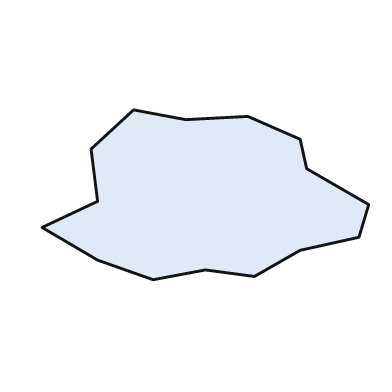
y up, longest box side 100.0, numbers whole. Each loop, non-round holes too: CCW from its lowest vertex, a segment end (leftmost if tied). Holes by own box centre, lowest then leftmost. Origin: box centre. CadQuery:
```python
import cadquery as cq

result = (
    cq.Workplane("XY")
    .moveTo(-16.0, -26.0)
    .lineTo(0.0, -23.0)
    .lineTo(15.0, -25.0)
    .lineTo(29.0, -17.0)
    .lineTo(47.0, -13.0)
    .lineTo(50.0, -3.0)
    .lineTo(31.0, 8.0)
    .lineTo(29.0, 17.0)
    .lineTo(13.0, 24.0)
    .lineTo(-6.0, 23.0)
    .lineTo(-22.0, 26.0)
    .lineTo(-35.0, 14.0)
    .lineTo(-33.0, -2.0)
    .lineTo(-50.0, -10.0)
    .lineTo(-33.0, -20.0)
    .close()
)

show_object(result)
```